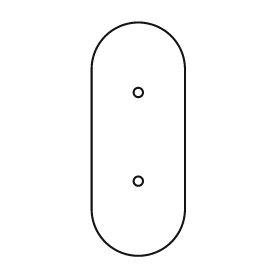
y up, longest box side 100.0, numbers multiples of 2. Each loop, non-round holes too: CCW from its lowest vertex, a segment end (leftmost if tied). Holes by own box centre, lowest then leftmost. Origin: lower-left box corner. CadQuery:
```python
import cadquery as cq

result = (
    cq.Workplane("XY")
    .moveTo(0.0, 20.0)
    .threePointArc((20.0, 0.0), (40.0, 20.0))
    .lineTo(40.0, 80.0)
    .threePointArc((20.0, 100.0), (0.0, 80.0))
    .close()
    .moveTo(20.0, 32.0)
    .circle(2.0)
    .moveTo(20.0, 70.0)
    .circle(2.0)
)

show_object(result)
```